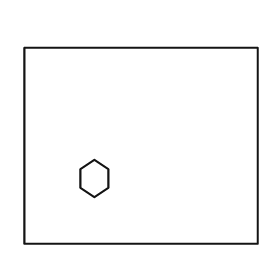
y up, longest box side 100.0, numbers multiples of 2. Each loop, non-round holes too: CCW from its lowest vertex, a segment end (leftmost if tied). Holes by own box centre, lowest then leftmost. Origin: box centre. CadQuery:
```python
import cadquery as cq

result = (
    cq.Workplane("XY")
    .moveTo(-50.0, -42.0)
    .lineTo(50.0, -42.0)
    .lineTo(50.0, 42.0)
    .lineTo(-50.0, 42.0)
    .close()
    .moveTo(-20.0, -22.0)
    .lineTo(-14.0, -18.0)
    .lineTo(-14.0, -10.0)
    .lineTo(-20.0, -6.0)
    .lineTo(-26.0, -10.0)
    .lineTo(-26.0, -18.0)
    .close()
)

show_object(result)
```